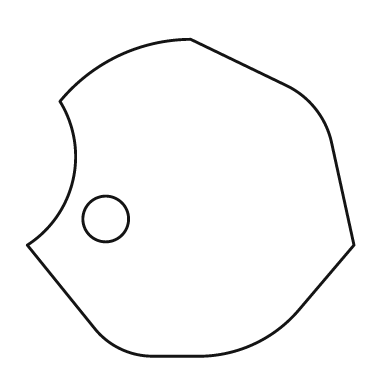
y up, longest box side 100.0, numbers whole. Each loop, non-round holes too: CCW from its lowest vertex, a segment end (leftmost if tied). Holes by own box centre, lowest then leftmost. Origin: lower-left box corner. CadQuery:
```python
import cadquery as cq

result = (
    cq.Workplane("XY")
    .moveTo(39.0, 0.0)
    .lineTo(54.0, 0.0)
    .threePointArc((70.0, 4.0), (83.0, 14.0))
    .lineTo(100.0, 34.0)
    .lineTo(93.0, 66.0)
    .threePointArc((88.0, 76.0), (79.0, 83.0))
    .lineTo(50.0, 97.0)
    .threePointArc((28.0, 92.0), (10.0, 78.0))
    .threePointArc((14.0, 54.0), (0.0, 34.0))
    .lineTo(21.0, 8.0)
    .threePointArc((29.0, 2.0), (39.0, 0.0))
    .close()
    .moveTo(24.0, 42.0)
    .circle(7.0)
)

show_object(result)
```